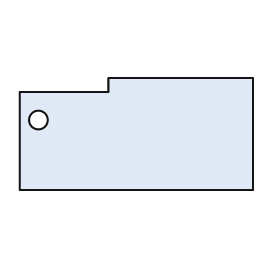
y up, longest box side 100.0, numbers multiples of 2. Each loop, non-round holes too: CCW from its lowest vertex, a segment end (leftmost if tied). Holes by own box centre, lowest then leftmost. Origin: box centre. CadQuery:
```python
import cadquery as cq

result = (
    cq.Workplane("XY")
    .moveTo(-50.0, -24.0)
    .lineTo(50.0, -24.0)
    .lineTo(50.0, 24.0)
    .lineTo(-12.0, 24.0)
    .lineTo(-12.0, 18.0)
    .lineTo(-50.0, 18.0)
    .close()
    .moveTo(-42.0, 6.0)
    .circle(4.0)
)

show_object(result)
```